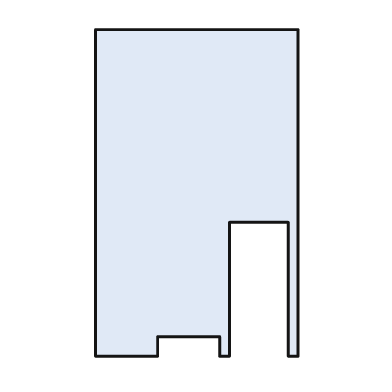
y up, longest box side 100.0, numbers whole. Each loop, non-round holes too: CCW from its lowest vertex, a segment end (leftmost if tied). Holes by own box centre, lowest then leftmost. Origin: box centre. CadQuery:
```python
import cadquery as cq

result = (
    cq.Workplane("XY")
    .moveTo(-31.0, -50.0)
    .lineTo(-12.0, -50.0)
    .lineTo(-12.0, -44.0)
    .lineTo(7.0, -44.0)
    .lineTo(7.0, -50.0)
    .lineTo(10.0, -50.0)
    .lineTo(10.0, -9.0)
    .lineTo(28.0, -9.0)
    .lineTo(28.0, -50.0)
    .lineTo(31.0, -50.0)
    .lineTo(31.0, 50.0)
    .lineTo(-31.0, 50.0)
    .close()
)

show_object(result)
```